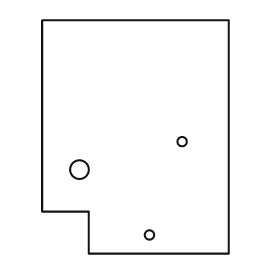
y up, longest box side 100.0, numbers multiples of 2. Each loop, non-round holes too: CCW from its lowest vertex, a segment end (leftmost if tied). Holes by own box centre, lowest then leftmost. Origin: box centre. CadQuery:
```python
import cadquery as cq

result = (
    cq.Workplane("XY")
    .moveTo(-20.0, -50.0)
    .lineTo(40.0, -50.0)
    .lineTo(40.0, 50.0)
    .lineTo(-40.0, 50.0)
    .lineTo(-40.0, -32.0)
    .lineTo(-20.0, -32.0)
    .close()
    .moveTo(6.0, -42.0)
    .circle(2.0)
    .moveTo(-24.0, -14.0)
    .circle(4.0)
    .moveTo(20.0, -2.0)
    .circle(2.0)
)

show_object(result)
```